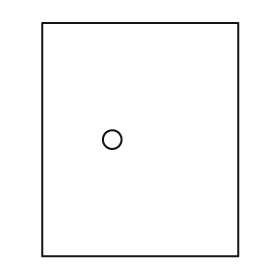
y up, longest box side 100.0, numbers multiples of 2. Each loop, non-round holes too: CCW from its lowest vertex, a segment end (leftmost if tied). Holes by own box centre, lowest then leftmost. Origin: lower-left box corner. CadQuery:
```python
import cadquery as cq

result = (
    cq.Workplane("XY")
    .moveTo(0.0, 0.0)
    .lineTo(84.0, 0.0)
    .lineTo(84.0, 100.0)
    .lineTo(0.0, 100.0)
    .close()
    .moveTo(30.0, 50.0)
    .circle(4.0)
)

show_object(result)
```